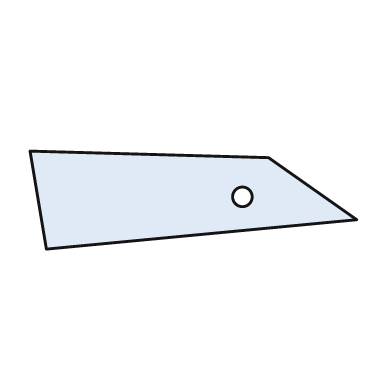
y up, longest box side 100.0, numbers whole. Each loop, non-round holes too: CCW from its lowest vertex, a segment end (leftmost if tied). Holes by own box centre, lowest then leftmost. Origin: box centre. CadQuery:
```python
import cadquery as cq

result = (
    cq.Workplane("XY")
    .moveTo(-45.0, -15.0)
    .lineTo(50.0, -6.0)
    .lineTo(23.0, 13.0)
    .lineTo(-50.0, 15.0)
    .close()
    .moveTo(15.0, 1.0)
    .circle(3.0)
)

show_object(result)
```